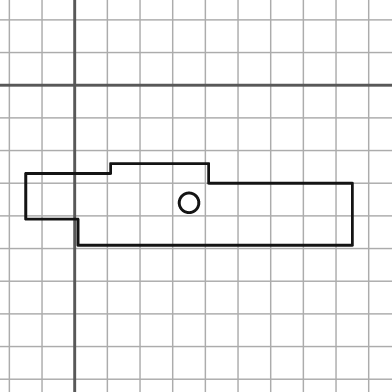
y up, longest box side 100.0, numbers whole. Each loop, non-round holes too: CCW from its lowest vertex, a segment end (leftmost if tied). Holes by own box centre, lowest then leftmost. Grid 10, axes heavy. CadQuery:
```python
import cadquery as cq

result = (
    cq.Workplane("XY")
    .moveTo(1.0, -49.0)
    .lineTo(85.0, -49.0)
    .lineTo(85.0, -30.0)
    .lineTo(41.0, -30.0)
    .lineTo(41.0, -24.0)
    .lineTo(11.0, -24.0)
    .lineTo(11.0, -27.0)
    .lineTo(-15.0, -27.0)
    .lineTo(-15.0, -41.0)
    .lineTo(1.0, -41.0)
    .close()
    .moveTo(35.0, -36.0)
    .circle(3.0)
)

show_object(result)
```